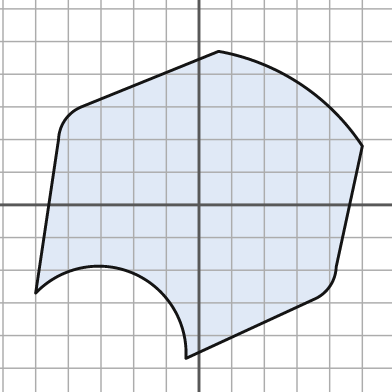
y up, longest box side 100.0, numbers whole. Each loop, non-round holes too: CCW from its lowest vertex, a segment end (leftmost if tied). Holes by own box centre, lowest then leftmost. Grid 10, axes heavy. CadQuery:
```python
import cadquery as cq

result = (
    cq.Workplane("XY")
    .moveTo(-4.0, -47.0)
    .lineTo(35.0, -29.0)
    .threePointArc((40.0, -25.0), (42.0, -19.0))
    .lineTo(50.0, 18.0)
    .threePointArc((31.0, 37.0), (6.0, 47.0))
    .lineTo(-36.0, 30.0)
    .threePointArc((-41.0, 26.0), (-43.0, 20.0))
    .lineTo(-50.0, -27.0)
    .threePointArc((-20.0, -21.0), (-4.0, -47.0))
    .close()
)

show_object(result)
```